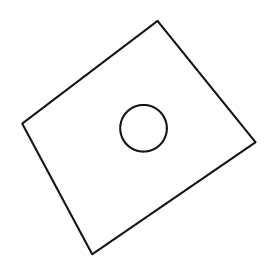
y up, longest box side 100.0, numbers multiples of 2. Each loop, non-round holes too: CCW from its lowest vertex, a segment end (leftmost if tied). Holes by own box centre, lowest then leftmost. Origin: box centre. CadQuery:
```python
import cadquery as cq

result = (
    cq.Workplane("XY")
    .moveTo(-20.0, -50.0)
    .lineTo(50.0, -2.0)
    .lineTo(8.0, 50.0)
    .lineTo(-50.0, 6.0)
    .close()
    .moveTo(2.0, 4.0)
    .circle(10.0)
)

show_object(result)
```